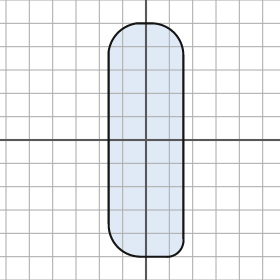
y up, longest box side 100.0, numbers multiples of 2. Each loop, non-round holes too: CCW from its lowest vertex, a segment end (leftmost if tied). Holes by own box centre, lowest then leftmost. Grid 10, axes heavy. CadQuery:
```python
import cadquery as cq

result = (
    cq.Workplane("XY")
    .moveTo(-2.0, -50.0)
    .lineTo(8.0, -50.0)
    .threePointArc((14.0, -48.0), (16.0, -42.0))
    .lineTo(16.0, 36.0)
    .threePointArc((12.0, 46.0), (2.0, 50.0))
    .lineTo(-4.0, 50.0)
    .threePointArc((-12.0, 46.0), (-16.0, 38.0))
    .lineTo(-16.0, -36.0)
    .threePointArc((-12.0, -46.0), (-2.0, -50.0))
    .close()
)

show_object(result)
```